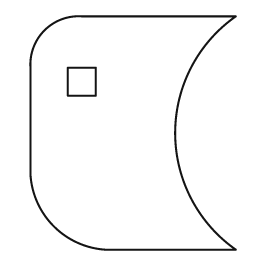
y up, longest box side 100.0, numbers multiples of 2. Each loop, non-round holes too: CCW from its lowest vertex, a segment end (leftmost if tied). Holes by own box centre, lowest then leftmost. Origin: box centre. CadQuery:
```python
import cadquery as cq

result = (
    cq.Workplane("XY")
    .moveTo(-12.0, -50.0)
    .lineTo(44.0, -50.0)
    .threePointArc((18.0, 0.0), (44.0, 50.0))
    .lineTo(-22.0, 50.0)
    .threePointArc((-38.0, 44.0), (-44.0, 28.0))
    .lineTo(-44.0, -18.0)
    .threePointArc((-34.0, -40.0), (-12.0, -50.0))
    .close()
    .moveTo(-28.0, 16.0)
    .lineTo(-16.0, 16.0)
    .lineTo(-16.0, 28.0)
    .lineTo(-28.0, 28.0)
    .close()
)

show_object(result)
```